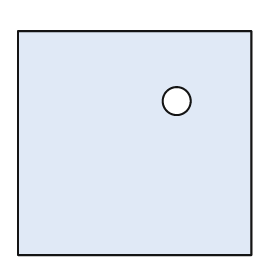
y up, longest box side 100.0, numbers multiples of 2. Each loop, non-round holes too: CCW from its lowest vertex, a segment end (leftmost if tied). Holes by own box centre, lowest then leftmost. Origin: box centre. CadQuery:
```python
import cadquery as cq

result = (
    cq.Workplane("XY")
    .moveTo(-50.0, -48.0)
    .lineTo(50.0, -48.0)
    .lineTo(50.0, 48.0)
    .lineTo(-50.0, 48.0)
    .close()
    .moveTo(18.0, 18.0)
    .circle(6.0)
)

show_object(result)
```